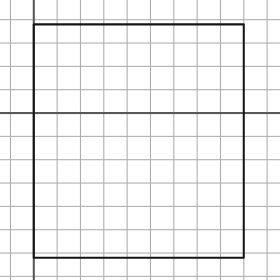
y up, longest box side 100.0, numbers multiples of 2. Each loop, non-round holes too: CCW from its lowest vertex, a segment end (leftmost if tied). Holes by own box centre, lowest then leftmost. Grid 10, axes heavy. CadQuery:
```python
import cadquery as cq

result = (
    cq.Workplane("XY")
    .moveTo(0.0, -62.0)
    .lineTo(90.0, -62.0)
    .lineTo(90.0, 38.0)
    .lineTo(0.0, 38.0)
    .close()
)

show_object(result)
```